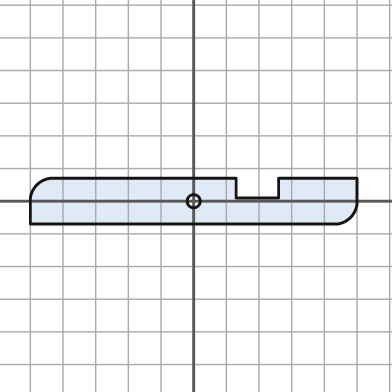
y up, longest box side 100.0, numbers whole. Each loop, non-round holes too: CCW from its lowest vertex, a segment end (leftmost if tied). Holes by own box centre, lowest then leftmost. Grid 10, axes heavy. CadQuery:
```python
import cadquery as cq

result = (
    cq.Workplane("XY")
    .moveTo(-50.0, -7.0)
    .lineTo(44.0, -7.0)
    .threePointArc((48.0, -5.0), (50.0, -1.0))
    .lineTo(50.0, 7.0)
    .lineTo(26.0, 7.0)
    .lineTo(26.0, 1.0)
    .lineTo(13.0, 1.0)
    .lineTo(13.0, 7.0)
    .lineTo(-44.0, 7.0)
    .threePointArc((-48.0, 5.0), (-50.0, 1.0))
    .close()
    .moveTo(0.0, 0.0)
    .circle(2.0)
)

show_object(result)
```